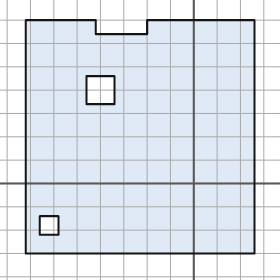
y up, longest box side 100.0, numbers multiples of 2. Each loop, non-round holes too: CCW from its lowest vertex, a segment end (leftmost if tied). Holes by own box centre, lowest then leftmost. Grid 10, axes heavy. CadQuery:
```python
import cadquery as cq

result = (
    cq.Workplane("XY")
    .moveTo(-72.0, -30.0)
    .lineTo(26.0, -30.0)
    .lineTo(26.0, 70.0)
    .lineTo(-20.0, 70.0)
    .lineTo(-20.0, 64.0)
    .lineTo(-42.0, 64.0)
    .lineTo(-42.0, 70.0)
    .lineTo(-72.0, 70.0)
    .close()
    .moveTo(-66.0, -22.0)
    .lineTo(-58.0, -22.0)
    .lineTo(-58.0, -14.0)
    .lineTo(-66.0, -14.0)
    .close()
    .moveTo(-46.0, 34.0)
    .lineTo(-34.0, 34.0)
    .lineTo(-34.0, 46.0)
    .lineTo(-46.0, 46.0)
    .close()
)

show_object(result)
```